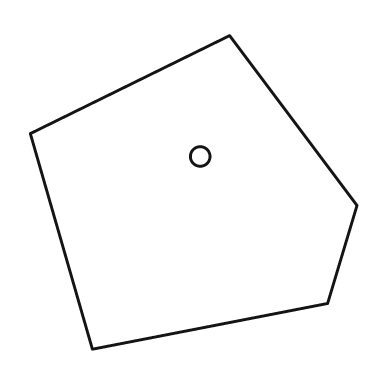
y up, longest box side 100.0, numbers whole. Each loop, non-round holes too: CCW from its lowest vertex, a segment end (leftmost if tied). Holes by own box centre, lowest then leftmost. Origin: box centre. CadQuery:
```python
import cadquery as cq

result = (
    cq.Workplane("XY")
    .moveTo(-31.0, -48.0)
    .lineTo(41.0, -34.0)
    .lineTo(50.0, -4.0)
    .lineTo(11.0, 48.0)
    .lineTo(-50.0, 18.0)
    .close()
    .moveTo(2.0, 11.0)
    .circle(3.0)
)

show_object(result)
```